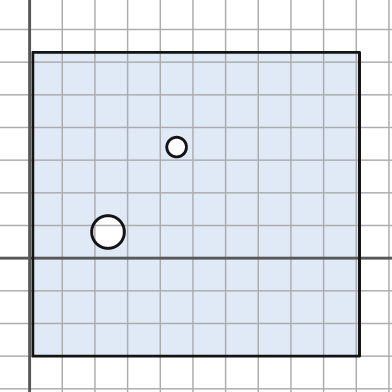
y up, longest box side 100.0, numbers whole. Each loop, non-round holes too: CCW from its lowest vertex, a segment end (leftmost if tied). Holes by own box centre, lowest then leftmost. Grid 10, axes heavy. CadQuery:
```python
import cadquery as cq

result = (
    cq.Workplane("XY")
    .moveTo(1.0, -30.0)
    .lineTo(101.0, -30.0)
    .lineTo(101.0, 63.0)
    .lineTo(1.0, 63.0)
    .close()
    .moveTo(24.0, 8.0)
    .circle(5.0)
    .moveTo(45.0, 34.0)
    .circle(3.0)
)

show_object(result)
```